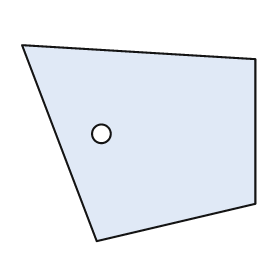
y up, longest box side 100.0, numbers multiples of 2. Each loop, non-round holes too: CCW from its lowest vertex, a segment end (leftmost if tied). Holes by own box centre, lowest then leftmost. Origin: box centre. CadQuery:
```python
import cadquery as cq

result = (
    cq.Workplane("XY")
    .moveTo(-18.0, -42.0)
    .lineTo(50.0, -26.0)
    .lineTo(50.0, 36.0)
    .lineTo(-50.0, 42.0)
    .close()
    .moveTo(-16.0, 4.0)
    .circle(4.0)
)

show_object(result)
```